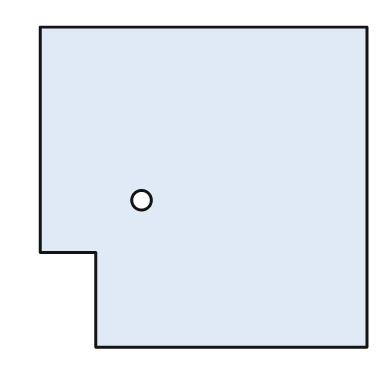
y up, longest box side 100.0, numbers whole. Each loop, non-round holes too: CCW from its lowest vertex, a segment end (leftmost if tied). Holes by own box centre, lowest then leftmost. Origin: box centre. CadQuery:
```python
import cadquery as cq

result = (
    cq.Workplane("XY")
    .moveTo(-33.0, -49.0)
    .lineTo(50.0, -49.0)
    .lineTo(50.0, 49.0)
    .lineTo(-50.0, 49.0)
    .lineTo(-50.0, -20.0)
    .lineTo(-33.0, -20.0)
    .close()
    .moveTo(-19.0, -4.0)
    .circle(3.0)
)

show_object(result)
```